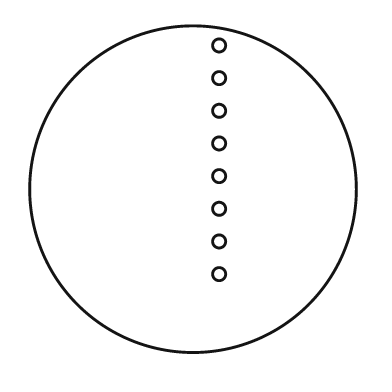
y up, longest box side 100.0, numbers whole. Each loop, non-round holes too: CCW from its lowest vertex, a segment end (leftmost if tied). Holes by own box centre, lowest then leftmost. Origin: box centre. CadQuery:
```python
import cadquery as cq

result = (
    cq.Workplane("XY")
    .moveTo(0.0, 0.0)
    .circle(50.0)
    .moveTo(8.0, -26.0)
    .circle(2.0)
    .moveTo(8.0, -16.0)
    .circle(2.0)
    .moveTo(8.0, -6.0)
    .circle(2.0)
    .moveTo(8.0, 4.0)
    .circle(2.0)
    .moveTo(8.0, 14.0)
    .circle(2.0)
    .moveTo(8.0, 24.0)
    .circle(2.0)
    .moveTo(8.0, 34.0)
    .circle(2.0)
    .moveTo(8.0, 44.0)
    .circle(2.0)
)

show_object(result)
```